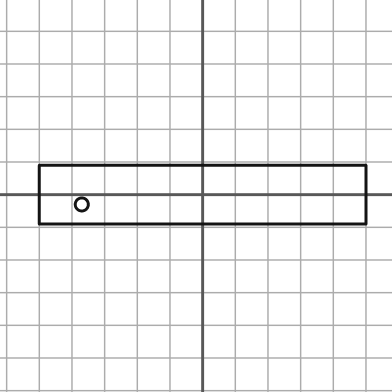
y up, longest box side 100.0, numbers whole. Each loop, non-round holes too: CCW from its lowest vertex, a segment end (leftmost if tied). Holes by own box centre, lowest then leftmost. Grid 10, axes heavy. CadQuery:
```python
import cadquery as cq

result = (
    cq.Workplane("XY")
    .moveTo(-50.0, -9.0)
    .lineTo(50.0, -9.0)
    .lineTo(50.0, 9.0)
    .lineTo(-50.0, 9.0)
    .close()
    .moveTo(-37.0, -3.0)
    .circle(2.0)
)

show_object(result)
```